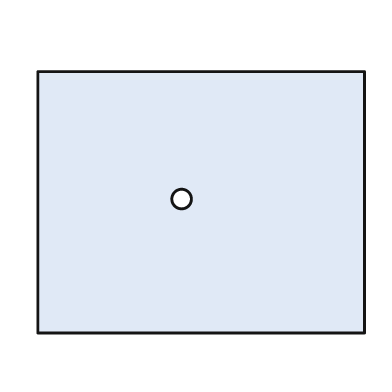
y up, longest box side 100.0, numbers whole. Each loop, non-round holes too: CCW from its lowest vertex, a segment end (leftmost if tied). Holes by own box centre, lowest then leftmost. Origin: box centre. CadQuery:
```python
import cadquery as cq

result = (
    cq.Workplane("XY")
    .moveTo(-50.0, -40.0)
    .lineTo(50.0, -40.0)
    .lineTo(50.0, 40.0)
    .lineTo(-50.0, 40.0)
    .close()
    .moveTo(-6.0, 1.0)
    .circle(3.0)
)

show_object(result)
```